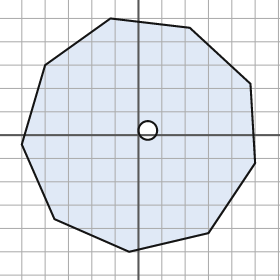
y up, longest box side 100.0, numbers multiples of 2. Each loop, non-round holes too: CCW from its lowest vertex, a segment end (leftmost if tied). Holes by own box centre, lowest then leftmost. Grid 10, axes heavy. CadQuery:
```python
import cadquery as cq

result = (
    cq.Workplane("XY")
    .moveTo(-4.0, -50.0)
    .lineTo(30.0, -42.0)
    .lineTo(50.0, -12.0)
    .lineTo(48.0, 22.0)
    .lineTo(22.0, 46.0)
    .lineTo(-12.0, 50.0)
    .lineTo(-40.0, 30.0)
    .lineTo(-50.0, -4.0)
    .lineTo(-36.0, -36.0)
    .close()
    .moveTo(4.0, 2.0)
    .circle(4.0)
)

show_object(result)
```